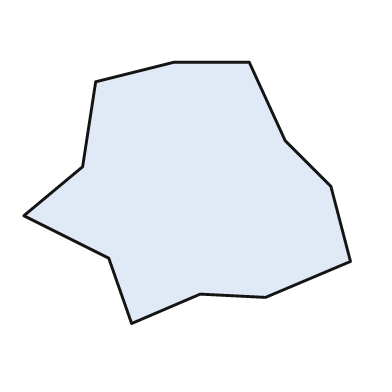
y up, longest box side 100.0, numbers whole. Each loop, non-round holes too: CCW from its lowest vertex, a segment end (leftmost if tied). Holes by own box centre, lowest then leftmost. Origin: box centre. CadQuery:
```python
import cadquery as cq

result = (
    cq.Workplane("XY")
    .moveTo(-17.0, -40.0)
    .lineTo(4.0, -31.0)
    .lineTo(24.0, -32.0)
    .lineTo(50.0, -21.0)
    .lineTo(44.0, 2.0)
    .lineTo(30.0, 16.0)
    .lineTo(19.0, 40.0)
    .lineTo(-4.0, 40.0)
    .lineTo(-28.0, 34.0)
    .lineTo(-32.0, 8.0)
    .lineTo(-50.0, -7.0)
    .lineTo(-24.0, -20.0)
    .close()
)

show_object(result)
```